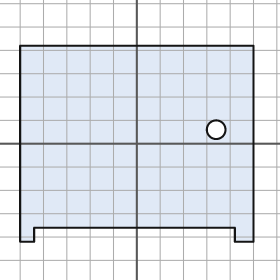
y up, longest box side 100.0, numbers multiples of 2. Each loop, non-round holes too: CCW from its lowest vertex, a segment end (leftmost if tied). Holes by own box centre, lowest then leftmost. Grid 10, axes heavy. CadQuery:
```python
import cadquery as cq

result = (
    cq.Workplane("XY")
    .moveTo(-50.0, -42.0)
    .lineTo(-44.0, -42.0)
    .lineTo(-44.0, -36.0)
    .lineTo(42.0, -36.0)
    .lineTo(42.0, -42.0)
    .lineTo(50.0, -42.0)
    .lineTo(50.0, 42.0)
    .lineTo(-50.0, 42.0)
    .close()
    .moveTo(34.0, 6.0)
    .circle(4.0)
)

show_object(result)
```